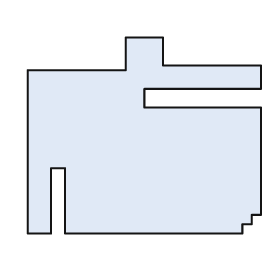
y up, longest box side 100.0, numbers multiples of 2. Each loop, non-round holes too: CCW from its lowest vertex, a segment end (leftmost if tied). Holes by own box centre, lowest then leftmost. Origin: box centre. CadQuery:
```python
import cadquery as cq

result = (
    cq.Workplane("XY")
    .moveTo(-50.0, -42.0)
    .lineTo(-40.0, -42.0)
    .lineTo(-40.0, -14.0)
    .lineTo(-34.0, -14.0)
    .lineTo(-34.0, -42.0)
    .lineTo(42.0, -42.0)
    .lineTo(42.0, -38.0)
    .lineTo(46.0, -38.0)
    .lineTo(46.0, -34.0)
    .lineTo(50.0, -34.0)
    .lineTo(50.0, 12.0)
    .lineTo(0.0, 12.0)
    .lineTo(0.0, 20.0)
    .lineTo(50.0, 20.0)
    .lineTo(50.0, 30.0)
    .lineTo(8.0, 30.0)
    .lineTo(8.0, 42.0)
    .lineTo(-8.0, 42.0)
    .lineTo(-8.0, 28.0)
    .lineTo(-50.0, 28.0)
    .close()
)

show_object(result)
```